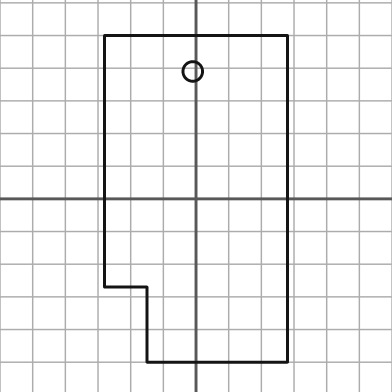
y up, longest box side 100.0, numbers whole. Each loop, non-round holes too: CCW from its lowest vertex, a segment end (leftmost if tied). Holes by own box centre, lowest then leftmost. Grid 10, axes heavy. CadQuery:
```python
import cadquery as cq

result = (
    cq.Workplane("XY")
    .moveTo(-15.0, -50.0)
    .lineTo(28.0, -50.0)
    .lineTo(28.0, 50.0)
    .lineTo(-28.0, 50.0)
    .lineTo(-28.0, -27.0)
    .lineTo(-15.0, -27.0)
    .close()
    .moveTo(-1.0, 39.0)
    .circle(3.0)
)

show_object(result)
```